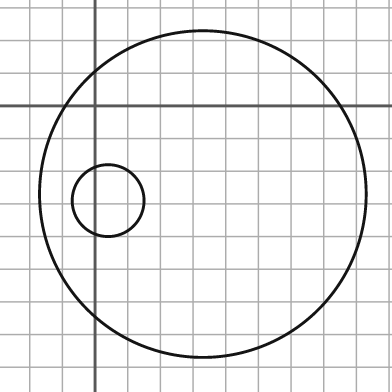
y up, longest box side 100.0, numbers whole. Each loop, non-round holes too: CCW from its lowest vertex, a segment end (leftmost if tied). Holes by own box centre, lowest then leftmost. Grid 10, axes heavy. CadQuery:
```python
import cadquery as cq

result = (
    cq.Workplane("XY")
    .moveTo(33.0, -27.0)
    .circle(50.0)
    .moveTo(4.0, -29.0)
    .circle(11.0)
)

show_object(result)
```